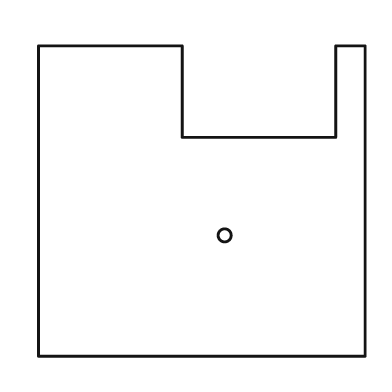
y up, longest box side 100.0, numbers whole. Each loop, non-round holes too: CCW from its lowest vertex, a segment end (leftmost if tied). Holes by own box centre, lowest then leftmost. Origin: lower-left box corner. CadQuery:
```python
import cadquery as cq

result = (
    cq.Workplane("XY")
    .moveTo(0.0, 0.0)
    .lineTo(100.0, 0.0)
    .lineTo(100.0, 95.0)
    .lineTo(91.0, 95.0)
    .lineTo(91.0, 67.0)
    .lineTo(44.0, 67.0)
    .lineTo(44.0, 95.0)
    .lineTo(0.0, 95.0)
    .close()
    .moveTo(57.0, 37.0)
    .circle(2.0)
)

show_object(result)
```